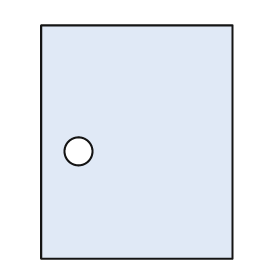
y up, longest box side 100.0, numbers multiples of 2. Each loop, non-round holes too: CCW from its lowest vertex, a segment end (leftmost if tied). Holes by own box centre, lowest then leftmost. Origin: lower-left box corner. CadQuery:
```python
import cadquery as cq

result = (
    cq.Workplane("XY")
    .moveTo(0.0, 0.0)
    .lineTo(82.0, 0.0)
    .lineTo(82.0, 100.0)
    .lineTo(0.0, 100.0)
    .close()
    .moveTo(16.0, 46.0)
    .circle(6.0)
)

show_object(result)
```